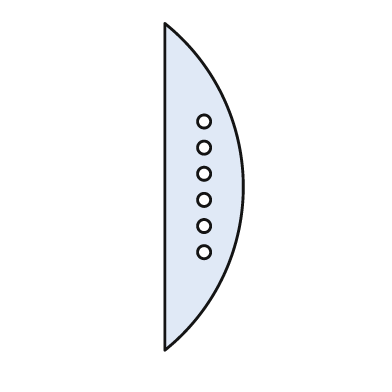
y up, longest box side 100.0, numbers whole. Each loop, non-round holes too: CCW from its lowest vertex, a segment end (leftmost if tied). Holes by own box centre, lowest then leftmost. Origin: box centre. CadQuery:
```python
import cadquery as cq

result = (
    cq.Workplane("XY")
    .moveTo(-12.0, -50.0)
    .threePointArc((12.0, 0.0), (-12.0, 50.0))
    .close()
    .moveTo(0.0, -20.0)
    .circle(2.0)
    .moveTo(0.0, -12.0)
    .circle(2.0)
    .moveTo(0.0, -4.0)
    .circle(2.0)
    .moveTo(0.0, 4.0)
    .circle(2.0)
    .moveTo(0.0, 12.0)
    .circle(2.0)
    .moveTo(0.0, 20.0)
    .circle(2.0)
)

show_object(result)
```